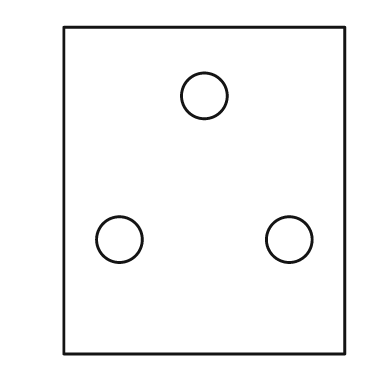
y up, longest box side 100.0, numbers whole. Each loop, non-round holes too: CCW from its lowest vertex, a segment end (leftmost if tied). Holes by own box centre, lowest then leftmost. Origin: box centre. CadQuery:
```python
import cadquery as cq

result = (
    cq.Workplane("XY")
    .moveTo(-43.0, -50.0)
    .lineTo(43.0, -50.0)
    .lineTo(43.0, 50.0)
    .lineTo(-43.0, 50.0)
    .close()
    .moveTo(-26.0, -15.0)
    .circle(7.0)
    .moveTo(26.0, -15.0)
    .circle(7.0)
    .moveTo(0.0, 29.0)
    .circle(7.0)
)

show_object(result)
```